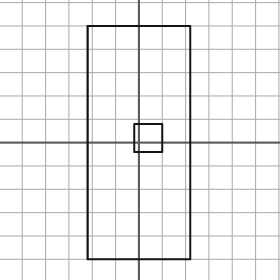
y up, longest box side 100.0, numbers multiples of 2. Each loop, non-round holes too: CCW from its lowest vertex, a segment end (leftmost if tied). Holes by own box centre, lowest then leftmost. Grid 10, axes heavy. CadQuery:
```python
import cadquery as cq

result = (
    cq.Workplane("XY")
    .moveTo(-22.0, -50.0)
    .lineTo(22.0, -50.0)
    .lineTo(22.0, 50.0)
    .lineTo(-22.0, 50.0)
    .close()
    .moveTo(-2.0, -4.0)
    .lineTo(10.0, -4.0)
    .lineTo(10.0, 8.0)
    .lineTo(-2.0, 8.0)
    .close()
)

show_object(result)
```